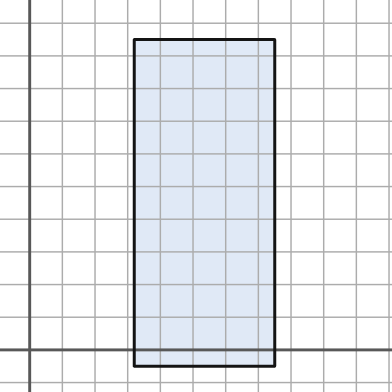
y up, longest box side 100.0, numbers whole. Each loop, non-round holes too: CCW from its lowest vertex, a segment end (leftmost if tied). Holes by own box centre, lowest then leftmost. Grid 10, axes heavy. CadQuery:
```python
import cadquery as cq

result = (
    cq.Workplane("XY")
    .moveTo(32.0, -5.0)
    .lineTo(75.0, -5.0)
    .lineTo(75.0, 95.0)
    .lineTo(32.0, 95.0)
    .close()
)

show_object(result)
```